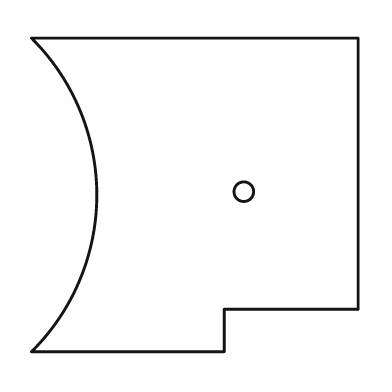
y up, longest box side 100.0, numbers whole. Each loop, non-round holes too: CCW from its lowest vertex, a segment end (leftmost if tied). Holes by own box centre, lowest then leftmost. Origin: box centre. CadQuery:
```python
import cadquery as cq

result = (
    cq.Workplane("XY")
    .moveTo(-50.0, -48.0)
    .lineTo(9.0, -48.0)
    .lineTo(9.0, -35.0)
    .lineTo(50.0, -35.0)
    .lineTo(50.0, 48.0)
    .lineTo(-50.0, 48.0)
    .threePointArc((-30.0, 0.0), (-50.0, -48.0))
    .close()
    .moveTo(15.0, 1.0)
    .circle(3.0)
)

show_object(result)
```